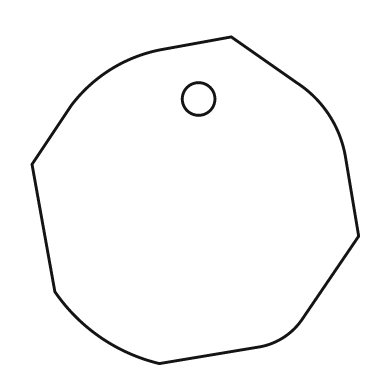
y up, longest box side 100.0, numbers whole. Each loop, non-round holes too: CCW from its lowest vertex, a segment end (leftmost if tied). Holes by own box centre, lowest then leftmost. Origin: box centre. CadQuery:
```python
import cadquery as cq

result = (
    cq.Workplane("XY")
    .moveTo(-11.0, -50.0)
    .lineTo(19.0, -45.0)
    .threePointArc((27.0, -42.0), (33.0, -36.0))
    .lineTo(50.0, -11.0)
    .lineTo(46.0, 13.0)
    .threePointArc((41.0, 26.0), (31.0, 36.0))
    .lineTo(11.0, 50.0)
    .lineTo(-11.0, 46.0)
    .threePointArc((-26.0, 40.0), (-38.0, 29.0))
    .lineTo(-50.0, 11.0)
    .lineTo(-43.0, -28.0)
    .threePointArc((-29.0, -42.0), (-11.0, -50.0))
    .close()
    .moveTo(1.0, 31.0)
    .circle(5.0)
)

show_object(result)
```